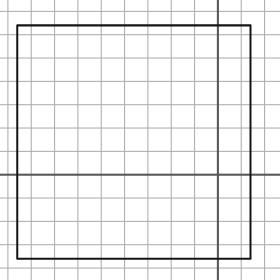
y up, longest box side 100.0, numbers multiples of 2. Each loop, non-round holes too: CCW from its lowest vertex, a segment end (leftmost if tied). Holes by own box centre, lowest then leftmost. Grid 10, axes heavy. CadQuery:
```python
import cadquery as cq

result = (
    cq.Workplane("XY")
    .moveTo(-86.0, -36.0)
    .lineTo(14.0, -36.0)
    .lineTo(14.0, 64.0)
    .lineTo(-86.0, 64.0)
    .close()
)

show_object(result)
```